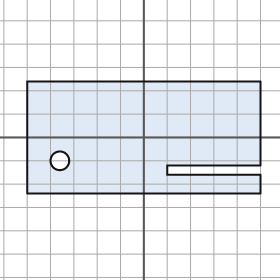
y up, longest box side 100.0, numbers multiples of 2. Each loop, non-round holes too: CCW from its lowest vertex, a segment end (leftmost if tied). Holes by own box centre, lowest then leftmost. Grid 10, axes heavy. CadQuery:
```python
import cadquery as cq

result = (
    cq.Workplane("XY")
    .moveTo(-50.0, -24.0)
    .lineTo(50.0, -24.0)
    .lineTo(50.0, -16.0)
    .lineTo(10.0, -16.0)
    .lineTo(10.0, -12.0)
    .lineTo(50.0, -12.0)
    .lineTo(50.0, 24.0)
    .lineTo(-50.0, 24.0)
    .close()
    .moveTo(-36.0, -10.0)
    .circle(4.0)
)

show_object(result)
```